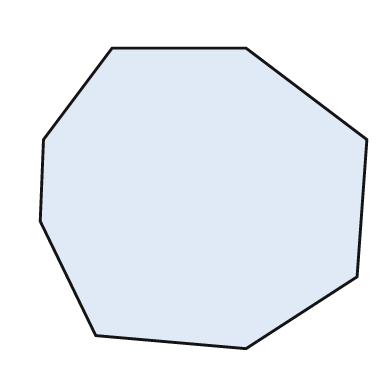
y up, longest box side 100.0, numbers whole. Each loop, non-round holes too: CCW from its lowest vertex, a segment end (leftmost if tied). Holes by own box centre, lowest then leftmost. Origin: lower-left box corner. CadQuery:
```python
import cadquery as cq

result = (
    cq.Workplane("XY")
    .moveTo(63.0, 0.0)
    .lineTo(97.0, 22.0)
    .lineTo(100.0, 64.0)
    .lineTo(63.0, 92.0)
    .lineTo(22.0, 92.0)
    .lineTo(1.0, 64.0)
    .lineTo(0.0, 39.0)
    .lineTo(17.0, 4.0)
    .close()
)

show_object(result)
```